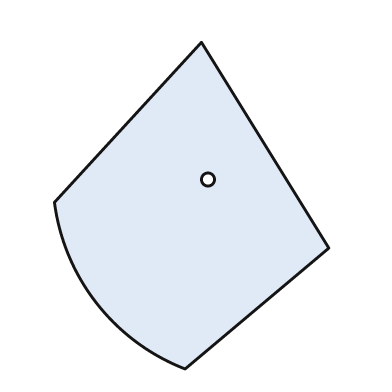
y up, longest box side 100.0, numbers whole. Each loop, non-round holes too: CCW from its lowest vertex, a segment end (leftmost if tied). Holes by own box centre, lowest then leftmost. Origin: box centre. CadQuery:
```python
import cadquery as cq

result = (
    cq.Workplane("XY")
    .moveTo(-2.0, -50.0)
    .lineTo(42.0, -13.0)
    .lineTo(3.0, 50.0)
    .lineTo(-42.0, 1.0)
    .threePointArc((-29.0, -30.0), (-2.0, -50.0))
    .close()
    .moveTo(5.0, 8.0)
    .circle(2.0)
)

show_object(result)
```